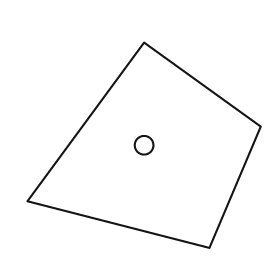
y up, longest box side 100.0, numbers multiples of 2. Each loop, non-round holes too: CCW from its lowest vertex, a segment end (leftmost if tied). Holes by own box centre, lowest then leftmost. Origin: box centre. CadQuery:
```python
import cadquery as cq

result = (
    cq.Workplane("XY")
    .moveTo(28.0, -44.0)
    .lineTo(50.0, 8.0)
    .lineTo(0.0, 44.0)
    .lineTo(-50.0, -24.0)
    .close()
    .moveTo(0.0, 0.0)
    .circle(4.0)
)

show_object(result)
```